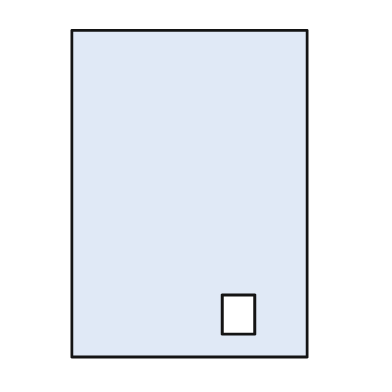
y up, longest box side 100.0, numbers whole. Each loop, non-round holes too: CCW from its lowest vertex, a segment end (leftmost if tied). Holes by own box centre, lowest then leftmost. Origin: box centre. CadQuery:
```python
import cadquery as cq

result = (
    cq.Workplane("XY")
    .moveTo(-36.0, -50.0)
    .lineTo(36.0, -50.0)
    .lineTo(36.0, 50.0)
    .lineTo(-36.0, 50.0)
    .close()
    .moveTo(10.0, -43.0)
    .lineTo(20.0, -43.0)
    .lineTo(20.0, -31.0)
    .lineTo(10.0, -31.0)
    .close()
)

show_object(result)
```